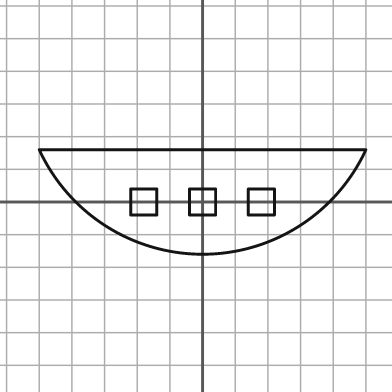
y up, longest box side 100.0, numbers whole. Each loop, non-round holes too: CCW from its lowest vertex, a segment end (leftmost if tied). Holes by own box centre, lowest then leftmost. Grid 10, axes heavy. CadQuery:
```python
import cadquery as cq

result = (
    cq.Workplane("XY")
    .moveTo(-50.0, 16.0)
    .threePointArc((0.0, -16.0), (50.0, 16.0))
    .close()
    .moveTo(-22.0, -4.0)
    .lineTo(-14.0, -4.0)
    .lineTo(-14.0, 4.0)
    .lineTo(-22.0, 4.0)
    .close()
    .moveTo(-4.0, -4.0)
    .lineTo(4.0, -4.0)
    .lineTo(4.0, 4.0)
    .lineTo(-4.0, 4.0)
    .close()
    .moveTo(14.0, -4.0)
    .lineTo(22.0, -4.0)
    .lineTo(22.0, 4.0)
    .lineTo(14.0, 4.0)
    .close()
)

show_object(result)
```